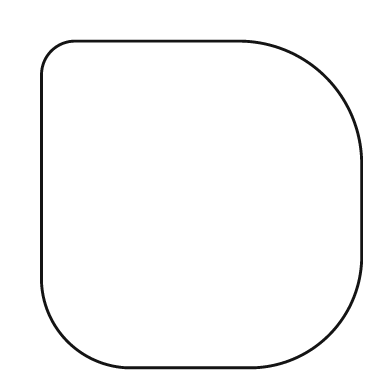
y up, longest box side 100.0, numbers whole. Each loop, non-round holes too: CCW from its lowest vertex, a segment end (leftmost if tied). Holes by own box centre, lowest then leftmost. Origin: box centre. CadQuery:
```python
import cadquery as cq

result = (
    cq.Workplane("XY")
    .moveTo(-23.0, -50.0)
    .lineTo(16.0, -50.0)
    .threePointArc((39.0, -40.0), (49.0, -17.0))
    .lineTo(49.0, 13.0)
    .threePointArc((38.0, 39.0), (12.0, 50.0))
    .lineTo(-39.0, 50.0)
    .threePointArc((-46.0, 47.0), (-49.0, 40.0))
    .lineTo(-49.0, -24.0)
    .threePointArc((-41.0, -42.0), (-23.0, -50.0))
    .close()
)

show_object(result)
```